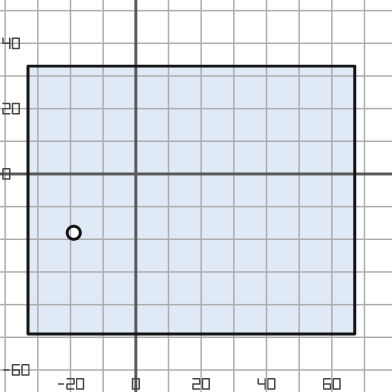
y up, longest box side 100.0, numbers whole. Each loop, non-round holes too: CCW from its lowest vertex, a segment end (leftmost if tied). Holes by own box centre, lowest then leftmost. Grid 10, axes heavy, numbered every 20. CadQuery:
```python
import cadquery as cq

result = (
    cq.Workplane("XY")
    .moveTo(-33.0, -49.0)
    .lineTo(67.0, -49.0)
    .lineTo(67.0, 33.0)
    .lineTo(-33.0, 33.0)
    .close()
    .moveTo(-19.0, -18.0)
    .circle(2.0)
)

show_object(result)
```